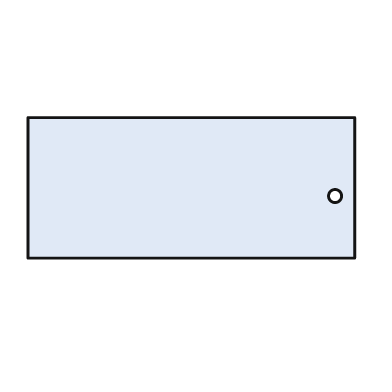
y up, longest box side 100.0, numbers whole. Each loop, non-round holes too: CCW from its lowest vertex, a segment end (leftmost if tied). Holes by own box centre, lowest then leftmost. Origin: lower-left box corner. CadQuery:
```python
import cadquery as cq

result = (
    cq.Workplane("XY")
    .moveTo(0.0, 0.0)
    .lineTo(100.0, 0.0)
    .lineTo(100.0, 43.0)
    .lineTo(0.0, 43.0)
    .close()
    .moveTo(94.0, 19.0)
    .circle(2.0)
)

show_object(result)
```